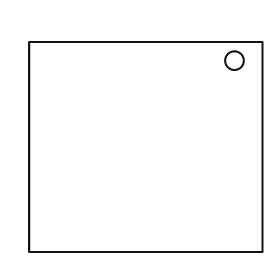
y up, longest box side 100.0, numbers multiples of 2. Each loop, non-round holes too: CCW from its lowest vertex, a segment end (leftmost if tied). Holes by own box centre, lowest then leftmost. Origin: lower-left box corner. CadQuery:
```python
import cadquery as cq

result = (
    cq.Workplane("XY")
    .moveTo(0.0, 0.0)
    .lineTo(100.0, 0.0)
    .lineTo(100.0, 90.0)
    .lineTo(0.0, 90.0)
    .close()
    .moveTo(88.0, 82.0)
    .circle(4.0)
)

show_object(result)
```